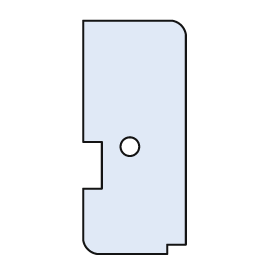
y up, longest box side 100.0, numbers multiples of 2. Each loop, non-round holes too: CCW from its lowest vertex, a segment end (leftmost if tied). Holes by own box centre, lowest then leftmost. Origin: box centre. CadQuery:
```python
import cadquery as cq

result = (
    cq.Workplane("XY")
    .moveTo(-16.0, -50.0)
    .lineTo(14.0, -50.0)
    .lineTo(14.0, -46.0)
    .lineTo(22.0, -46.0)
    .lineTo(22.0, 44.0)
    .threePointArc((20.0, 48.0), (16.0, 50.0))
    .lineTo(-22.0, 50.0)
    .lineTo(-22.0, -2.0)
    .lineTo(-14.0, -2.0)
    .lineTo(-14.0, -22.0)
    .lineTo(-22.0, -22.0)
    .lineTo(-22.0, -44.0)
    .threePointArc((-20.0, -48.0), (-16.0, -50.0))
    .close()
    .moveTo(-2.0, -4.0)
    .circle(4.0)
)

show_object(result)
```